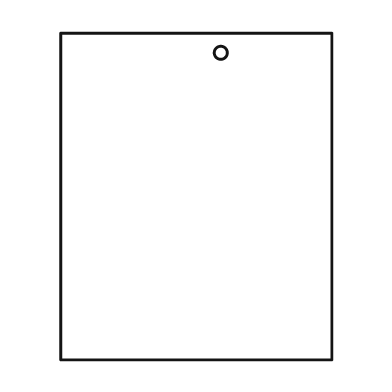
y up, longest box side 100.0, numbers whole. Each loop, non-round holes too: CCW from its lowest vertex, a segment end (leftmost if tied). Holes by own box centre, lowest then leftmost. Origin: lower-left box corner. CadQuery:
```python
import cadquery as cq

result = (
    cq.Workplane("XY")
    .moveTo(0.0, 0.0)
    .lineTo(83.0, 0.0)
    .lineTo(83.0, 100.0)
    .lineTo(0.0, 100.0)
    .close()
    .moveTo(49.0, 94.0)
    .circle(2.0)
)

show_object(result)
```